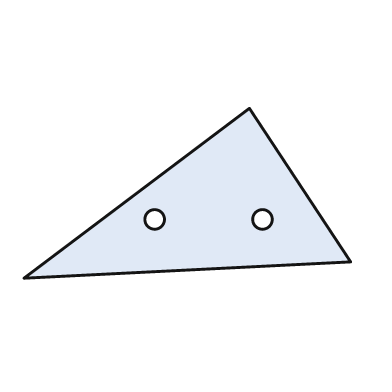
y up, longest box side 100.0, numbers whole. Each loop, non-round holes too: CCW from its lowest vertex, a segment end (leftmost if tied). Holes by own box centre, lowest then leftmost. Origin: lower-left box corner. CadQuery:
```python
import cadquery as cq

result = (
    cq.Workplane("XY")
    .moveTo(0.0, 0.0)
    .lineTo(100.0, 5.0)
    .lineTo(69.0, 52.0)
    .close()
    .moveTo(40.0, 18.0)
    .circle(3.0)
    .moveTo(73.0, 18.0)
    .circle(3.0)
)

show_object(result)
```